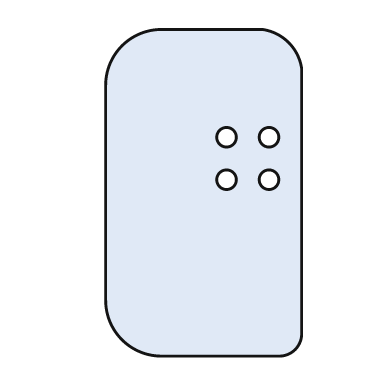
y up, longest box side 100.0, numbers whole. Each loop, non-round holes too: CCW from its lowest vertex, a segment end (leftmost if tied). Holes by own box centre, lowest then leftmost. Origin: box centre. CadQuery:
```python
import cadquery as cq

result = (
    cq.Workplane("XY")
    .moveTo(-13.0, -50.0)
    .lineTo(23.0, -50.0)
    .threePointArc((28.0, -48.0), (30.0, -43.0))
    .lineTo(30.0, 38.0)
    .threePointArc((26.0, 46.0), (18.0, 50.0))
    .lineTo(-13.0, 50.0)
    .threePointArc((-25.0, 45.0), (-30.0, 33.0))
    .lineTo(-30.0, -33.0)
    .threePointArc((-25.0, -45.0), (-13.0, -50.0))
    .close()
    .moveTo(7.0, 4.0)
    .circle(3.0)
    .moveTo(20.0, 4.0)
    .circle(3.0)
    .moveTo(7.0, 17.0)
    .circle(3.0)
    .moveTo(20.0, 17.0)
    .circle(3.0)
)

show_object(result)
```